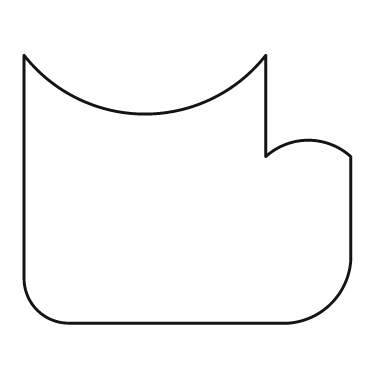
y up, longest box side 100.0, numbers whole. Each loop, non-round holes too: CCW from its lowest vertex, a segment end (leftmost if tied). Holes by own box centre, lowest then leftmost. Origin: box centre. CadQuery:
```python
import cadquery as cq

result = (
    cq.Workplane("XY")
    .moveTo(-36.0, -41.0)
    .lineTo(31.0, -41.0)
    .threePointArc((44.0, -35.0), (50.0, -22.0))
    .lineTo(50.0, 10.0)
    .threePointArc((37.0, 15.0), (24.0, 10.0))
    .lineTo(24.0, 41.0)
    .threePointArc((-13.0, 23.0), (-50.0, 41.0))
    .lineTo(-50.0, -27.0)
    .threePointArc((-46.0, -37.0), (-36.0, -41.0))
    .close()
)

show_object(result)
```